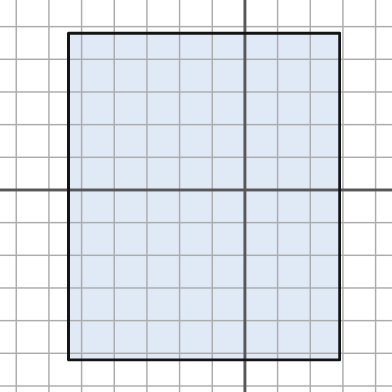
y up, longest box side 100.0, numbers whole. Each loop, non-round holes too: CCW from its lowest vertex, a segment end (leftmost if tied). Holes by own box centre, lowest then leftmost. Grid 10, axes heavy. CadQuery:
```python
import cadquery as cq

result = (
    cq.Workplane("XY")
    .moveTo(-54.0, -52.0)
    .lineTo(29.0, -52.0)
    .lineTo(29.0, 48.0)
    .lineTo(-54.0, 48.0)
    .close()
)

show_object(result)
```